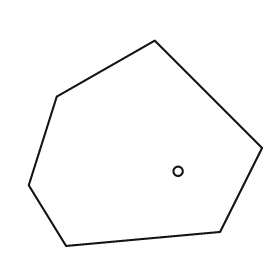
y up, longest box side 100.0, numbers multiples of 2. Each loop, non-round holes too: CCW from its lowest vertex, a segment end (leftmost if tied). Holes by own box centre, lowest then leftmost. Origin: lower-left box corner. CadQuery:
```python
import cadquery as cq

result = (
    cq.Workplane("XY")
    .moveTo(16.0, 0.0)
    .lineTo(82.0, 6.0)
    .lineTo(100.0, 42.0)
    .lineTo(54.0, 88.0)
    .lineTo(12.0, 64.0)
    .lineTo(0.0, 26.0)
    .close()
    .moveTo(64.0, 32.0)
    .circle(2.0)
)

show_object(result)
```